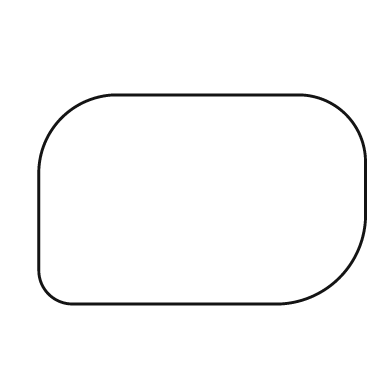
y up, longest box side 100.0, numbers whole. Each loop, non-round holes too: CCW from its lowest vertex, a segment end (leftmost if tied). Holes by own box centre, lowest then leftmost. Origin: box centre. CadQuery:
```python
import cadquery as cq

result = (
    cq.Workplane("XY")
    .moveTo(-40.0, -32.0)
    .lineTo(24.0, -32.0)
    .threePointArc((42.0, -24.0), (50.0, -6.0))
    .lineTo(50.0, 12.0)
    .threePointArc((44.0, 26.0), (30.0, 32.0))
    .lineTo(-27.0, 32.0)
    .threePointArc((-43.0, 25.0), (-50.0, 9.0))
    .lineTo(-50.0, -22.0)
    .threePointArc((-47.0, -29.0), (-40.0, -32.0))
    .close()
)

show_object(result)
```